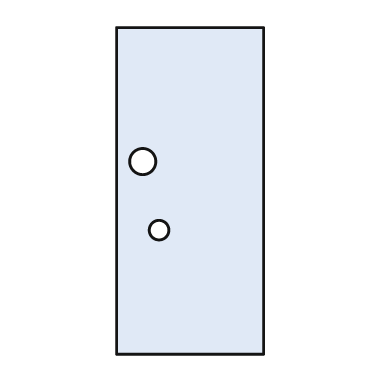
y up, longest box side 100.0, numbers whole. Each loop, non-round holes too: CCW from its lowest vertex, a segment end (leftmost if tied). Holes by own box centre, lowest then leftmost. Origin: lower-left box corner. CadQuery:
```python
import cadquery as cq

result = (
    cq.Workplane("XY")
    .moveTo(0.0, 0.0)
    .lineTo(45.0, 0.0)
    .lineTo(45.0, 100.0)
    .lineTo(0.0, 100.0)
    .close()
    .moveTo(13.0, 38.0)
    .circle(3.0)
    .moveTo(8.0, 59.0)
    .circle(4.0)
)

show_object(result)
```